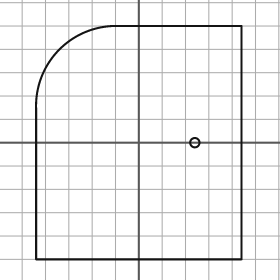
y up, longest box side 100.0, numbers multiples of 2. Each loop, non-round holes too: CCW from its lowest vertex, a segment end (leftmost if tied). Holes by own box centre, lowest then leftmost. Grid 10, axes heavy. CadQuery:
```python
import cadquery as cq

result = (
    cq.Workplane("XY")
    .moveTo(-44.0, -50.0)
    .lineTo(44.0, -50.0)
    .lineTo(44.0, 50.0)
    .lineTo(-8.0, 50.0)
    .threePointArc((-34.0, 40.0), (-44.0, 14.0))
    .close()
    .moveTo(24.0, 0.0)
    .circle(2.0)
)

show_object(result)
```